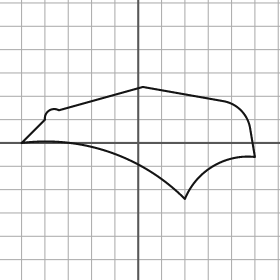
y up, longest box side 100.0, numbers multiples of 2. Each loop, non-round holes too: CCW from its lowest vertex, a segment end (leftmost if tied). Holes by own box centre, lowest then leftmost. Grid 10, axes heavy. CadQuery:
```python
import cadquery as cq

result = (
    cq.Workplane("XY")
    .moveTo(20.0, -24.0)
    .threePointArc((32.0, -10.0), (50.0, -6.0))
    .lineTo(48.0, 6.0)
    .threePointArc((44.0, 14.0), (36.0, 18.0))
    .lineTo(2.0, 24.0)
    .lineTo(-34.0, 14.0)
    .threePointArc((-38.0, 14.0), (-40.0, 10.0))
    .lineTo(-50.0, 0.0)
    .threePointArc((-12.0, -4.0), (20.0, -24.0))
    .close()
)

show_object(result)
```